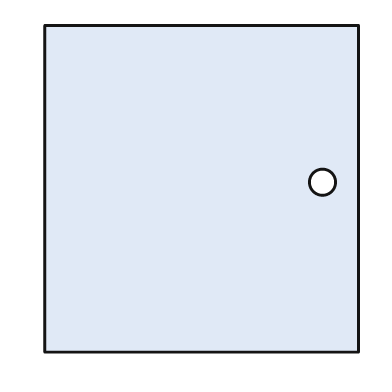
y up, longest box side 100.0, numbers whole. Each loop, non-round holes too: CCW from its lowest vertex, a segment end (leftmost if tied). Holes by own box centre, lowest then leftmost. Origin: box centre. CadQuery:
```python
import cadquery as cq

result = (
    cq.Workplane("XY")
    .moveTo(-48.0, -50.0)
    .lineTo(48.0, -50.0)
    .lineTo(48.0, 50.0)
    .lineTo(-48.0, 50.0)
    .close()
    .moveTo(37.0, 2.0)
    .circle(4.0)
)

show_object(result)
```